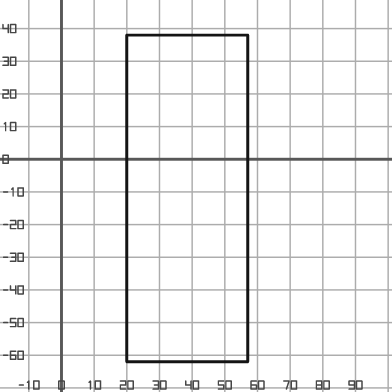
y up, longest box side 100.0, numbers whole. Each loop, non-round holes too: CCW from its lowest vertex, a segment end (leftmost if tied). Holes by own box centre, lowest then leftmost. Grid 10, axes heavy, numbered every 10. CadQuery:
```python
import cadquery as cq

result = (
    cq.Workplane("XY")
    .moveTo(20.0, -62.0)
    .lineTo(57.0, -62.0)
    .lineTo(57.0, 38.0)
    .lineTo(20.0, 38.0)
    .close()
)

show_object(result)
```